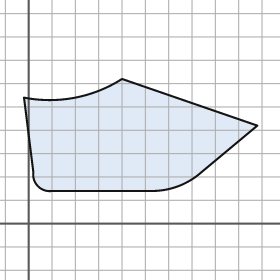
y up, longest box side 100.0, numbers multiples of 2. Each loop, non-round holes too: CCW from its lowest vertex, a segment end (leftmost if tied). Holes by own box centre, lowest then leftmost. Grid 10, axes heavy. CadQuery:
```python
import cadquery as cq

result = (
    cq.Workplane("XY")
    .moveTo(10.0, 14.0)
    .lineTo(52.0, 14.0)
    .threePointArc((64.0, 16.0), (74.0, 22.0))
    .lineTo(98.0, 42.0)
    .lineTo(40.0, 62.0)
    .threePointArc((20.0, 54.0), (-2.0, 54.0))
    .lineTo(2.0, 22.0)
    .threePointArc((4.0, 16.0), (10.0, 14.0))
    .close()
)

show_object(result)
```